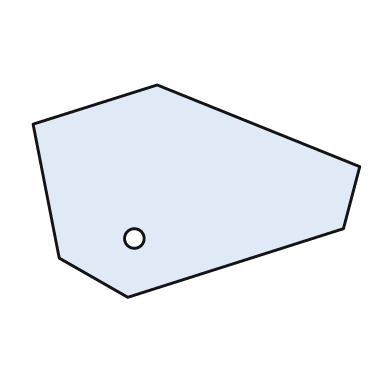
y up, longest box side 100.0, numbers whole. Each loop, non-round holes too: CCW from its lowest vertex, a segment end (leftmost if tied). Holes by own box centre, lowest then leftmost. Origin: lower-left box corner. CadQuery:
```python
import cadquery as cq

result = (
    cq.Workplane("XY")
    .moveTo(29.0, 0.0)
    .lineTo(95.0, 21.0)
    .lineTo(100.0, 40.0)
    .lineTo(38.0, 65.0)
    .lineTo(0.0, 53.0)
    .lineTo(8.0, 12.0)
    .close()
    .moveTo(31.0, 18.0)
    .circle(3.0)
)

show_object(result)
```